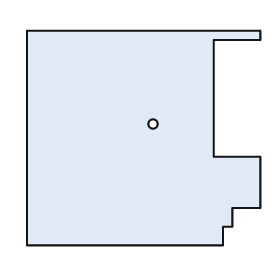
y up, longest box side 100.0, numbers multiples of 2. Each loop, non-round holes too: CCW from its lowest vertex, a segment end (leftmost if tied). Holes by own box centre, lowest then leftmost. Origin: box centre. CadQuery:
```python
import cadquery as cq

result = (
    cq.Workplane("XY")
    .moveTo(-50.0, -46.0)
    .lineTo(34.0, -46.0)
    .lineTo(34.0, -38.0)
    .lineTo(38.0, -38.0)
    .lineTo(38.0, -30.0)
    .lineTo(50.0, -30.0)
    .lineTo(50.0, -8.0)
    .lineTo(30.0, -8.0)
    .lineTo(30.0, 42.0)
    .lineTo(50.0, 42.0)
    .lineTo(50.0, 46.0)
    .lineTo(-50.0, 46.0)
    .close()
    .moveTo(4.0, 6.0)
    .circle(2.0)
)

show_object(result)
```